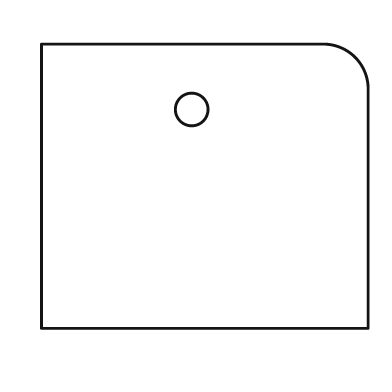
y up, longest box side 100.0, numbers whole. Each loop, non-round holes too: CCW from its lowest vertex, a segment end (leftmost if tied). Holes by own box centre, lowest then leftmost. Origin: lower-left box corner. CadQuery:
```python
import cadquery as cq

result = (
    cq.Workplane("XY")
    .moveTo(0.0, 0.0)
    .lineTo(100.0, 0.0)
    .lineTo(100.0, 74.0)
    .threePointArc((96.0, 83.0), (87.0, 87.0))
    .lineTo(0.0, 87.0)
    .close()
    .moveTo(46.0, 67.0)
    .circle(5.0)
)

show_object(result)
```